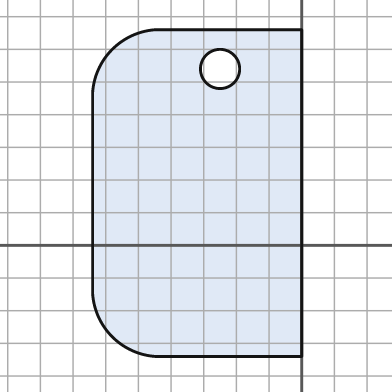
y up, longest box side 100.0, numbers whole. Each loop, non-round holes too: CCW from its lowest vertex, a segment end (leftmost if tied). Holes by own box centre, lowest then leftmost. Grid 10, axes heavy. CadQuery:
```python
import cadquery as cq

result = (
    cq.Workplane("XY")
    .moveTo(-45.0, -34.0)
    .lineTo(0.0, -34.0)
    .lineTo(0.0, 66.0)
    .lineTo(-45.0, 66.0)
    .threePointArc((-58.0, 60.0), (-64.0, 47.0))
    .lineTo(-64.0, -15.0)
    .threePointArc((-58.0, -28.0), (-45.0, -34.0))
    .close()
    .moveTo(-25.0, 54.0)
    .circle(6.0)
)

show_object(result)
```